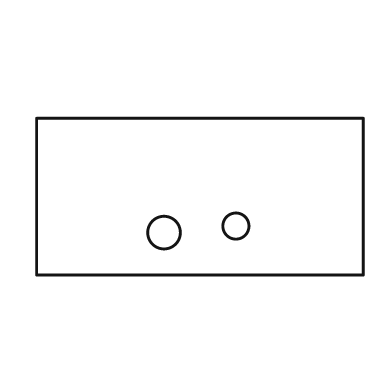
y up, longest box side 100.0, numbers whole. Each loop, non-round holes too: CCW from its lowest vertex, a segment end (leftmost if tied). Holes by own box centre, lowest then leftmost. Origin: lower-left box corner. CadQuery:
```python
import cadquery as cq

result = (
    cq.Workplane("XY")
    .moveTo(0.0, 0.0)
    .lineTo(100.0, 0.0)
    .lineTo(100.0, 48.0)
    .lineTo(0.0, 48.0)
    .close()
    .moveTo(39.0, 13.0)
    .circle(5.0)
    .moveTo(61.0, 15.0)
    .circle(4.0)
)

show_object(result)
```